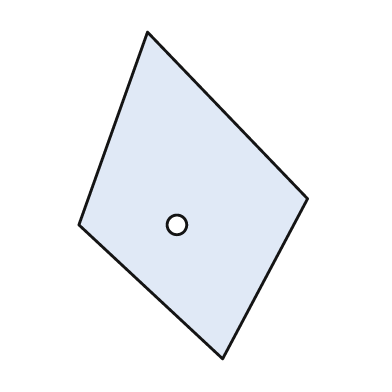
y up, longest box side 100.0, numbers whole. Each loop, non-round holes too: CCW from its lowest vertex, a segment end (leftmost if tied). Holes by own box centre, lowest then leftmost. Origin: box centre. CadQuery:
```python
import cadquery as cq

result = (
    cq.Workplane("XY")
    .moveTo(9.0, -50.0)
    .lineTo(35.0, -1.0)
    .lineTo(-14.0, 50.0)
    .lineTo(-35.0, -9.0)
    .close()
    .moveTo(-5.0, -9.0)
    .circle(3.0)
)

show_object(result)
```